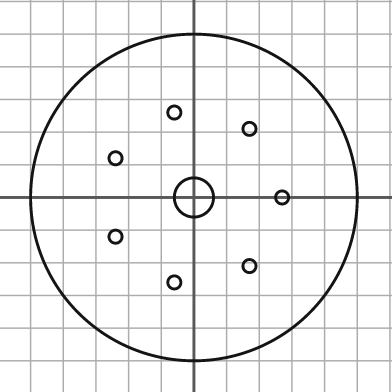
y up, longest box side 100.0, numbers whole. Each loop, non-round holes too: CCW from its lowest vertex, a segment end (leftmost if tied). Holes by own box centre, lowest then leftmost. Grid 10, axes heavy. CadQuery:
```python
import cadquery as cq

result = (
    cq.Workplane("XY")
    .moveTo(0.0, 0.0)
    .circle(50.0)
    .moveTo(-6.0, -26.0)
    .circle(2.0)
    .moveTo(17.0, -21.0)
    .circle(2.0)
    .moveTo(-24.0, -12.0)
    .circle(2.0)
    .moveTo(0.0, 0.0)
    .circle(6.0)
    .moveTo(27.0, 0.0)
    .circle(2.0)
    .moveTo(-24.0, 12.0)
    .circle(2.0)
    .moveTo(17.0, 21.0)
    .circle(2.0)
    .moveTo(-6.0, 26.0)
    .circle(2.0)
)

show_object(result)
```